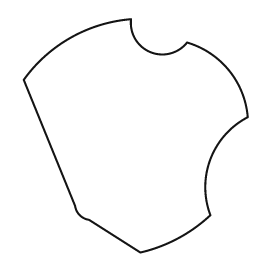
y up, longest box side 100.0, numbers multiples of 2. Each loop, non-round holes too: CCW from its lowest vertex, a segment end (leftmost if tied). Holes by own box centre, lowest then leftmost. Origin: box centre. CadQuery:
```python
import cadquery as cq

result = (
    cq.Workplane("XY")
    .moveTo(2.0, -50.0)
    .threePointArc((18.0, -44.0), (32.0, -34.0))
    .threePointArc((32.0, -10.0), (48.0, 8.0))
    .threePointArc((40.0, 28.0), (22.0, 40.0))
    .threePointArc((6.0, 36.0), (-2.0, 50.0))
    .threePointArc((-28.0, 42.0), (-48.0, 24.0))
    .lineTo(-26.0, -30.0)
    .threePointArc((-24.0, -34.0), (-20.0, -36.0))
    .close()
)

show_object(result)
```